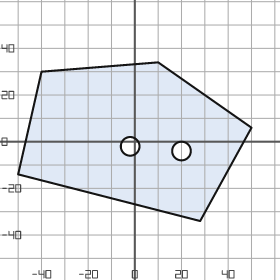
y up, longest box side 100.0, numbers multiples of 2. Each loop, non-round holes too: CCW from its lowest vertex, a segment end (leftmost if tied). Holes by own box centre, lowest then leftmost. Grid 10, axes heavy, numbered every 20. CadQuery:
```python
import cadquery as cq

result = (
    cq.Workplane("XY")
    .moveTo(28.0, -34.0)
    .lineTo(50.0, 6.0)
    .lineTo(10.0, 34.0)
    .lineTo(-40.0, 30.0)
    .lineTo(-50.0, -14.0)
    .close()
    .moveTo(20.0, -4.0)
    .circle(4.0)
    .moveTo(-2.0, -2.0)
    .circle(4.0)
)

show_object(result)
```